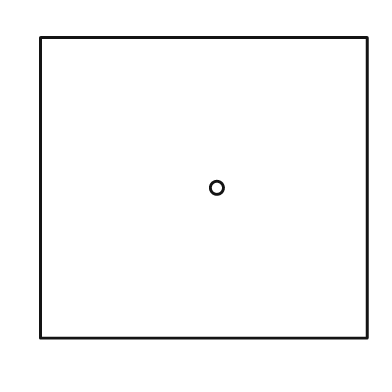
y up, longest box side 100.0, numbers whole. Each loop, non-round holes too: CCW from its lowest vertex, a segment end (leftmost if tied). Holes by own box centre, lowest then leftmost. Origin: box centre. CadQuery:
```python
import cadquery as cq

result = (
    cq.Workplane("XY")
    .moveTo(-50.0, -46.0)
    .lineTo(50.0, -46.0)
    .lineTo(50.0, 46.0)
    .lineTo(-50.0, 46.0)
    .close()
    .moveTo(4.0, 0.0)
    .circle(2.0)
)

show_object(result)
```